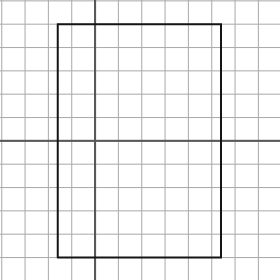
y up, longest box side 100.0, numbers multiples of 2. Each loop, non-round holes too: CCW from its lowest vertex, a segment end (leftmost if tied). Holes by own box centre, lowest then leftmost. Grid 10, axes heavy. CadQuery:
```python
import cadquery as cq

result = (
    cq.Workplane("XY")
    .moveTo(-16.0, -50.0)
    .lineTo(54.0, -50.0)
    .lineTo(54.0, 50.0)
    .lineTo(-16.0, 50.0)
    .close()
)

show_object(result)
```